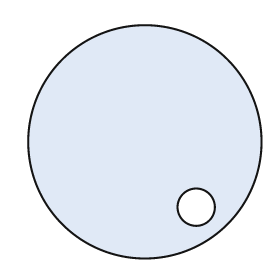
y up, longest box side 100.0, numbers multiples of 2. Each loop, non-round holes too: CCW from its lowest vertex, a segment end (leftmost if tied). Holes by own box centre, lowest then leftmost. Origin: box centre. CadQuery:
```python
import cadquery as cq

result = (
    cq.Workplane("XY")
    .moveTo(0.0, 0.0)
    .circle(50.0)
    .moveTo(22.0, -28.0)
    .circle(8.0)
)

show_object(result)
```